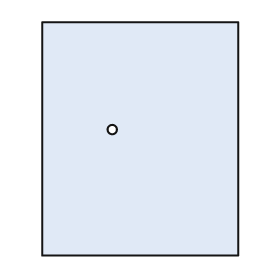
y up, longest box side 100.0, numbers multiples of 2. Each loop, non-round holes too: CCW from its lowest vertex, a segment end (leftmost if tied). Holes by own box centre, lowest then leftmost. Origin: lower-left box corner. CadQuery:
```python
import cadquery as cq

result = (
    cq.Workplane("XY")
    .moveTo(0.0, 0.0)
    .lineTo(84.0, 0.0)
    .lineTo(84.0, 100.0)
    .lineTo(0.0, 100.0)
    .close()
    .moveTo(30.0, 54.0)
    .circle(2.0)
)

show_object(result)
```